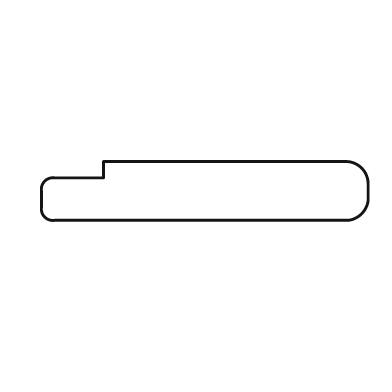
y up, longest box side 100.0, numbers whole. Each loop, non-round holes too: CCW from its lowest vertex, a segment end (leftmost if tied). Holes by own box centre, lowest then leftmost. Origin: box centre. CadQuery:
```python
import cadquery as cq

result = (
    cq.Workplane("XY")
    .moveTo(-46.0, -9.0)
    .lineTo(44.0, -9.0)
    .threePointArc((48.0, -7.0), (50.0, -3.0))
    .lineTo(50.0, 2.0)
    .threePointArc((48.0, 7.0), (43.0, 9.0))
    .lineTo(-31.0, 9.0)
    .lineTo(-31.0, 4.0)
    .lineTo(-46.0, 4.0)
    .threePointArc((-49.0, 3.0), (-50.0, 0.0))
    .lineTo(-50.0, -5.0)
    .threePointArc((-49.0, -8.0), (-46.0, -9.0))
    .close()
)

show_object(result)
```